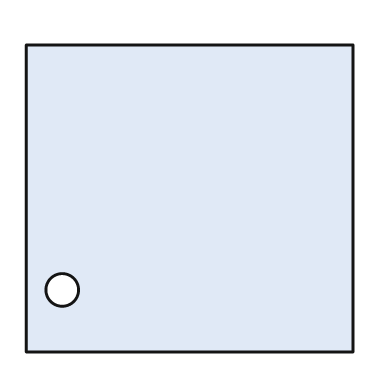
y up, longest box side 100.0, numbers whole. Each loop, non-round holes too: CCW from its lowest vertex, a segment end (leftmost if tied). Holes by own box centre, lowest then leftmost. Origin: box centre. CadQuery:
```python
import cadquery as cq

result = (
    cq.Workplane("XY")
    .moveTo(-50.0, -47.0)
    .lineTo(50.0, -47.0)
    .lineTo(50.0, 47.0)
    .lineTo(-50.0, 47.0)
    .close()
    .moveTo(-39.0, -28.0)
    .circle(5.0)
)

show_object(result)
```